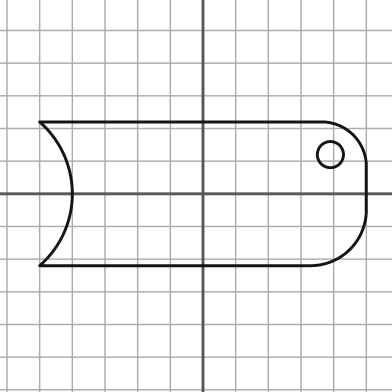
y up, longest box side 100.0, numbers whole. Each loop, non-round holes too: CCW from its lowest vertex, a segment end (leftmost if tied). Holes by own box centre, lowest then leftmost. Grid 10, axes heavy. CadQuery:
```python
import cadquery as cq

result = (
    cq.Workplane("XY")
    .moveTo(-50.0, -22.0)
    .lineTo(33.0, -22.0)
    .threePointArc((45.0, -17.0), (50.0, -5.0))
    .lineTo(50.0, 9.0)
    .threePointArc((46.0, 18.0), (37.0, 22.0))
    .lineTo(-50.0, 22.0)
    .threePointArc((-40.0, 0.0), (-50.0, -22.0))
    .close()
    .moveTo(39.0, 12.0)
    .circle(4.0)
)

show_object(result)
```